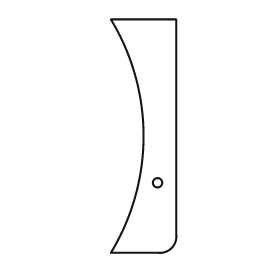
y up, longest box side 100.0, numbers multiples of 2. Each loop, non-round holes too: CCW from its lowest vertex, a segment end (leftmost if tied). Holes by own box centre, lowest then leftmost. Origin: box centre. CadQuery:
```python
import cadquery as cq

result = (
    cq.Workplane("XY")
    .moveTo(-14.0, -50.0)
    .lineTo(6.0, -50.0)
    .threePointArc((12.0, -48.0), (14.0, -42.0))
    .lineTo(14.0, 50.0)
    .lineTo(-14.0, 50.0)
    .threePointArc((0.0, 0.0), (-14.0, -50.0))
    .close()
    .moveTo(6.0, -20.0)
    .circle(2.0)
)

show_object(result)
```